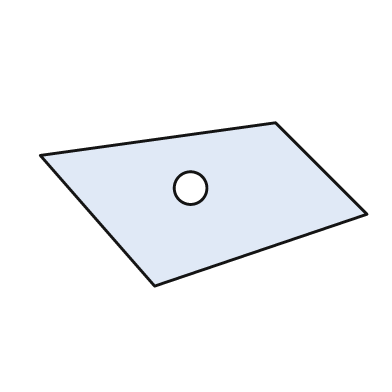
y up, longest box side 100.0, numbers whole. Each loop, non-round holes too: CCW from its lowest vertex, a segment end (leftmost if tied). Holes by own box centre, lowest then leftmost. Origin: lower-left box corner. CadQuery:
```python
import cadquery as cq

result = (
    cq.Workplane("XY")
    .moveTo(35.0, 0.0)
    .lineTo(100.0, 22.0)
    .lineTo(72.0, 50.0)
    .lineTo(0.0, 40.0)
    .close()
    .moveTo(46.0, 30.0)
    .circle(5.0)
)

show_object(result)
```